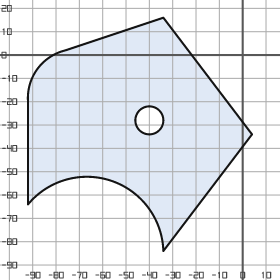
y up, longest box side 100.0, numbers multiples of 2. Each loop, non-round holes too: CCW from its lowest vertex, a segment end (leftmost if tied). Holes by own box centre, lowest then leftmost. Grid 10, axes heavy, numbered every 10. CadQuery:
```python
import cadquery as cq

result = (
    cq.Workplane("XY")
    .moveTo(-34.0, -84.0)
    .lineTo(4.0, -34.0)
    .lineTo(-34.0, 16.0)
    .lineTo(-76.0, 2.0)
    .threePointArc((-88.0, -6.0), (-92.0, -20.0))
    .lineTo(-92.0, -64.0)
    .threePointArc((-56.0, -54.0), (-34.0, -84.0))
    .close()
    .moveTo(-40.0, -28.0)
    .circle(6.0)
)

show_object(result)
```